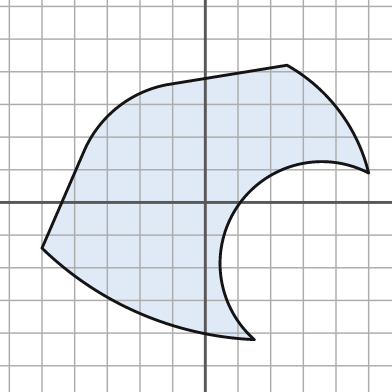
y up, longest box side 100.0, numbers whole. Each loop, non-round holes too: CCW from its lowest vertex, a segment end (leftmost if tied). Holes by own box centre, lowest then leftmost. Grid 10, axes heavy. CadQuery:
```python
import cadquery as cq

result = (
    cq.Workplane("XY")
    .moveTo(15.0, -42.0)
    .threePointArc((10.0, -1.0), (50.0, 9.0))
    .threePointArc((41.0, 28.0), (25.0, 42.0))
    .lineTo(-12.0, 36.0)
    .threePointArc((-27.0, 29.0), (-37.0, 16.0))
    .lineTo(-50.0, -14.0)
    .threePointArc((-20.0, -34.0), (15.0, -42.0))
    .close()
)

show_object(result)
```